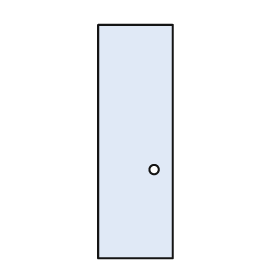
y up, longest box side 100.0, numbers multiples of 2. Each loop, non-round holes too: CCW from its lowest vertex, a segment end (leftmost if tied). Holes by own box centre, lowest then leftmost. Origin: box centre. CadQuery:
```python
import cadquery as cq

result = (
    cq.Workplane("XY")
    .moveTo(-16.0, -50.0)
    .lineTo(16.0, -50.0)
    .lineTo(16.0, 50.0)
    .lineTo(-16.0, 50.0)
    .close()
    .moveTo(8.0, -12.0)
    .circle(2.0)
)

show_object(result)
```